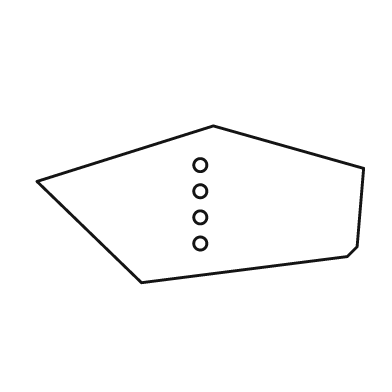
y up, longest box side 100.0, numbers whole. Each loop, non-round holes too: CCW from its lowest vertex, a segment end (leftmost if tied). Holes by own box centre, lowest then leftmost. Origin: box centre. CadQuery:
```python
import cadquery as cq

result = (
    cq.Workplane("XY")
    .moveTo(-18.0, -24.0)
    .lineTo(45.0, -16.0)
    .lineTo(48.0, -13.0)
    .lineTo(50.0, 11.0)
    .lineTo(4.0, 24.0)
    .lineTo(-50.0, 7.0)
    .close()
    .moveTo(0.0, -12.0)
    .circle(2.0)
    .moveTo(0.0, -4.0)
    .circle(2.0)
    .moveTo(0.0, 4.0)
    .circle(2.0)
    .moveTo(0.0, 12.0)
    .circle(2.0)
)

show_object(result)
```